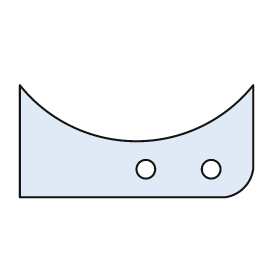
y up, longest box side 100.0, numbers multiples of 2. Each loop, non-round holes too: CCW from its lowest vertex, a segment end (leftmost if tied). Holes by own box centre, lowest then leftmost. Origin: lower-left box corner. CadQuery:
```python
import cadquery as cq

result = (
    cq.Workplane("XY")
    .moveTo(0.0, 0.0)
    .lineTo(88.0, 0.0)
    .threePointArc((96.0, 4.0), (100.0, 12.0))
    .lineTo(100.0, 48.0)
    .threePointArc((50.0, 24.0), (0.0, 48.0))
    .close()
    .moveTo(54.0, 12.0)
    .circle(4.0)
    .moveTo(82.0, 12.0)
    .circle(4.0)
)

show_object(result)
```